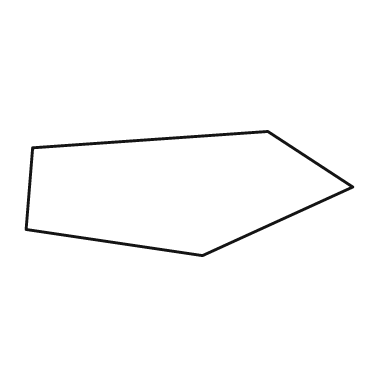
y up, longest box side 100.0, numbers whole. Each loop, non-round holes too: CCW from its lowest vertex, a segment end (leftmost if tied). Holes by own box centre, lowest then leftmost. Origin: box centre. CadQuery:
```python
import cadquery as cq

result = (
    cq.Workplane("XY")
    .moveTo(4.0, -19.0)
    .lineTo(50.0, 2.0)
    .lineTo(24.0, 19.0)
    .lineTo(-48.0, 14.0)
    .lineTo(-50.0, -11.0)
    .close()
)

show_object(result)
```